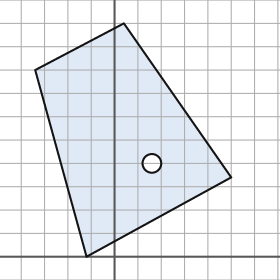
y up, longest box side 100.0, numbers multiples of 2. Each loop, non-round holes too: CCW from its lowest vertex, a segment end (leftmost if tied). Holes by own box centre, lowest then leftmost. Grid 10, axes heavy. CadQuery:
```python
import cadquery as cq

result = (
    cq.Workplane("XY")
    .moveTo(-12.0, 0.0)
    .lineTo(50.0, 34.0)
    .lineTo(4.0, 100.0)
    .lineTo(-34.0, 80.0)
    .close()
    .moveTo(16.0, 40.0)
    .circle(4.0)
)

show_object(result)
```